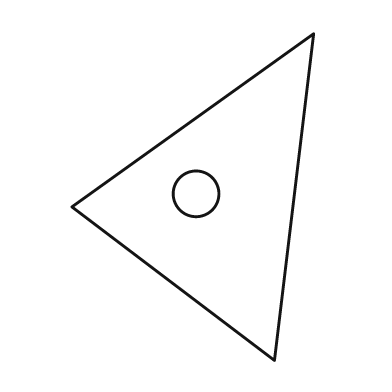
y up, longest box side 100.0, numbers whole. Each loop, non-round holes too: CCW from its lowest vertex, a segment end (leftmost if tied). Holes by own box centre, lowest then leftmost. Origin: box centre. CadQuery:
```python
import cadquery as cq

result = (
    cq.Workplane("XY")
    .moveTo(25.0, -50.0)
    .lineTo(37.0, 50.0)
    .lineTo(-37.0, -3.0)
    .close()
    .moveTo(1.0, 1.0)
    .circle(7.0)
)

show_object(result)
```